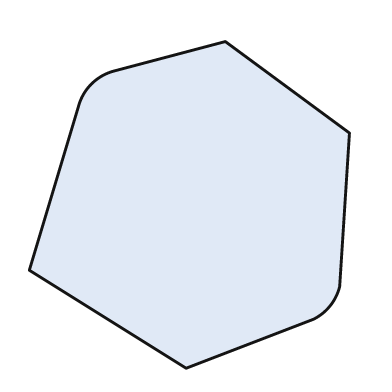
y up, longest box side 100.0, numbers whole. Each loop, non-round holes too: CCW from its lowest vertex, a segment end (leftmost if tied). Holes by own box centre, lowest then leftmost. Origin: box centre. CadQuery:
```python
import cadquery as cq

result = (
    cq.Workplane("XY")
    .moveTo(-1.0, -50.0)
    .lineTo(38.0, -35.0)
    .threePointArc((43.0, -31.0), (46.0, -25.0))
    .lineTo(49.0, 22.0)
    .lineTo(11.0, 50.0)
    .lineTo(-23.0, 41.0)
    .threePointArc((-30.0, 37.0), (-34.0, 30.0))
    .lineTo(-49.0, -20.0)
    .close()
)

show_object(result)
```